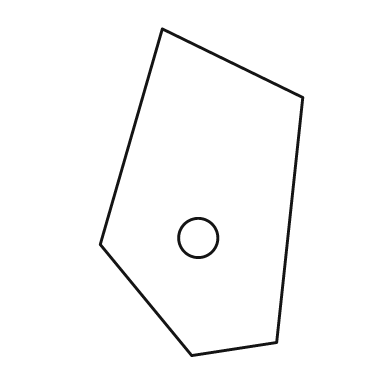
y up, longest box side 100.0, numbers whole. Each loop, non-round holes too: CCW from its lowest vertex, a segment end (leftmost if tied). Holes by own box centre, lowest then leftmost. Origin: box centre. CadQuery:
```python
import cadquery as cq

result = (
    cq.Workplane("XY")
    .moveTo(-3.0, -50.0)
    .lineTo(23.0, -46.0)
    .lineTo(31.0, 29.0)
    .lineTo(-12.0, 50.0)
    .lineTo(-31.0, -16.0)
    .close()
    .moveTo(-1.0, -14.0)
    .circle(6.0)
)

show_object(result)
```